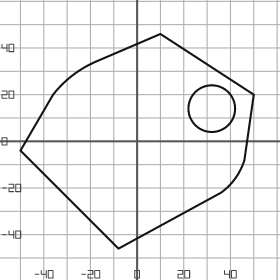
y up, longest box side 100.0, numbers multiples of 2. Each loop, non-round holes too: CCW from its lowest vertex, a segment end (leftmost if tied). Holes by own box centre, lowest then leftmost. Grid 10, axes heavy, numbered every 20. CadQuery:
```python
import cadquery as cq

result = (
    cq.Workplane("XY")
    .moveTo(-8.0, -46.0)
    .lineTo(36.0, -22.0)
    .threePointArc((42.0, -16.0), (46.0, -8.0))
    .lineTo(50.0, 20.0)
    .lineTo(10.0, 46.0)
    .lineTo(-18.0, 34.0)
    .threePointArc((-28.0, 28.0), (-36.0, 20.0))
    .lineTo(-50.0, -4.0)
    .close()
    .moveTo(32.0, 14.0)
    .circle(10.0)
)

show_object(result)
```